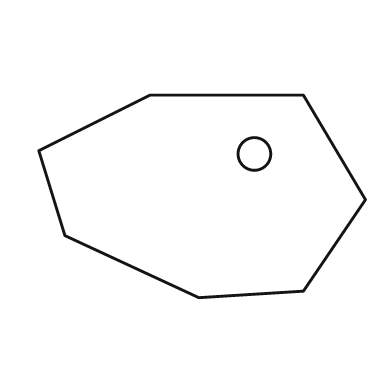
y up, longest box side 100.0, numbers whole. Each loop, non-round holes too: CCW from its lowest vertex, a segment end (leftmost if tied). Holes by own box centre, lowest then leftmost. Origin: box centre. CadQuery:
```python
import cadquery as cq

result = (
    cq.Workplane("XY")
    .moveTo(-1.0, -31.0)
    .lineTo(31.0, -29.0)
    .lineTo(50.0, -1.0)
    .lineTo(31.0, 31.0)
    .lineTo(-16.0, 31.0)
    .lineTo(-50.0, 14.0)
    .lineTo(-42.0, -12.0)
    .close()
    .moveTo(16.0, 13.0)
    .circle(5.0)
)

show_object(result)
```